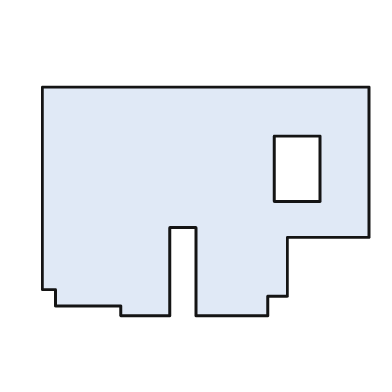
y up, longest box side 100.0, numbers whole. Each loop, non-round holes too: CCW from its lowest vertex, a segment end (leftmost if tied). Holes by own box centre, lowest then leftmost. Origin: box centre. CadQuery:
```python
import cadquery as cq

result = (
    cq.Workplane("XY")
    .moveTo(-26.0, -35.0)
    .lineTo(-11.0, -35.0)
    .lineTo(-11.0, -8.0)
    .lineTo(-3.0, -8.0)
    .lineTo(-3.0, -35.0)
    .lineTo(19.0, -35.0)
    .lineTo(19.0, -29.0)
    .lineTo(25.0, -29.0)
    .lineTo(25.0, -11.0)
    .lineTo(50.0, -11.0)
    .lineTo(50.0, 35.0)
    .lineTo(-50.0, 35.0)
    .lineTo(-50.0, -27.0)
    .lineTo(-46.0, -27.0)
    .lineTo(-46.0, -32.0)
    .lineTo(-26.0, -32.0)
    .close()
    .moveTo(21.0, 0.0)
    .lineTo(35.0, 0.0)
    .lineTo(35.0, 20.0)
    .lineTo(21.0, 20.0)
    .close()
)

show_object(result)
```